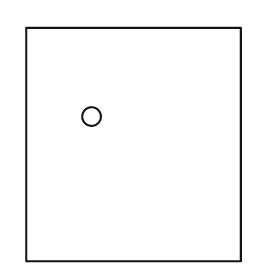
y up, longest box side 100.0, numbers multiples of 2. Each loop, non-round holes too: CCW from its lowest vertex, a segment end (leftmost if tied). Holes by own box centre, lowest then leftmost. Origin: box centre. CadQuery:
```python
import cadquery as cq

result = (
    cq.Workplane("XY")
    .moveTo(-46.0, -50.0)
    .lineTo(46.0, -50.0)
    .lineTo(46.0, 50.0)
    .lineTo(-46.0, 50.0)
    .close()
    .moveTo(-18.0, 12.0)
    .circle(4.0)
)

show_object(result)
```